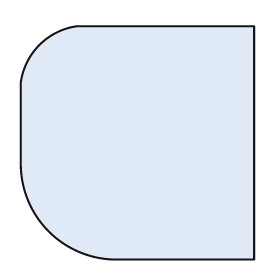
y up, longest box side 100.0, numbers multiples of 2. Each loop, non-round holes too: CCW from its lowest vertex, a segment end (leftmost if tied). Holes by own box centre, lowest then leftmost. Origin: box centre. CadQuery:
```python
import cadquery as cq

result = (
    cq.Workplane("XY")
    .moveTo(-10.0, -50.0)
    .lineTo(50.0, -50.0)
    .lineTo(50.0, 50.0)
    .lineTo(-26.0, 50.0)
    .threePointArc((-42.0, 42.0), (-50.0, 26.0))
    .lineTo(-50.0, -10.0)
    .threePointArc((-38.0, -38.0), (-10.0, -50.0))
    .close()
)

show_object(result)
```